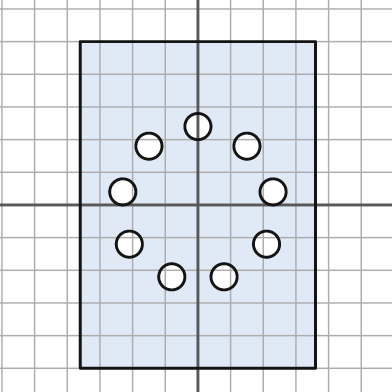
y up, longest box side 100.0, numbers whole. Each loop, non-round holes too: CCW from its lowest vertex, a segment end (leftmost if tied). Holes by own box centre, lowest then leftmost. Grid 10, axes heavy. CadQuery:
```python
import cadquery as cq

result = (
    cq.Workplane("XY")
    .moveTo(-36.0, -50.0)
    .lineTo(36.0, -50.0)
    .lineTo(36.0, 50.0)
    .lineTo(-36.0, 50.0)
    .close()
    .moveTo(-8.0, -22.0)
    .circle(4.0)
    .moveTo(8.0, -22.0)
    .circle(4.0)
    .moveTo(-21.0, -12.0)
    .circle(4.0)
    .moveTo(21.0, -12.0)
    .circle(4.0)
    .moveTo(-23.0, 4.0)
    .circle(4.0)
    .moveTo(23.0, 4.0)
    .circle(4.0)
    .moveTo(-15.0, 18.0)
    .circle(4.0)
    .moveTo(15.0, 18.0)
    .circle(4.0)
    .moveTo(0.0, 24.0)
    .circle(4.0)
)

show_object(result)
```